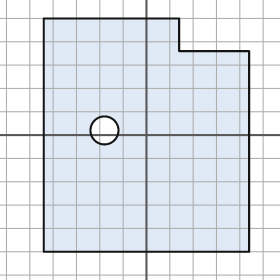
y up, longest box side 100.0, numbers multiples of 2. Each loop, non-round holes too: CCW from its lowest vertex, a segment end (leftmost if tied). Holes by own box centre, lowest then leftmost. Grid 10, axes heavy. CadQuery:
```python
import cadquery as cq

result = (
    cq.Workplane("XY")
    .moveTo(-44.0, -50.0)
    .lineTo(44.0, -50.0)
    .lineTo(44.0, 36.0)
    .lineTo(14.0, 36.0)
    .lineTo(14.0, 50.0)
    .lineTo(-44.0, 50.0)
    .close()
    .moveTo(-18.0, 2.0)
    .circle(6.0)
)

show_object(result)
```